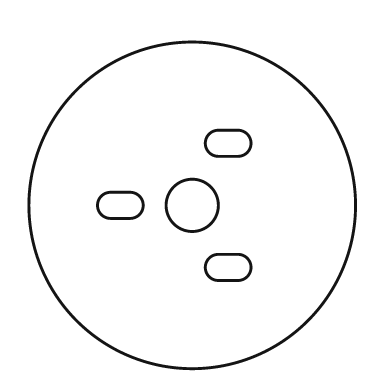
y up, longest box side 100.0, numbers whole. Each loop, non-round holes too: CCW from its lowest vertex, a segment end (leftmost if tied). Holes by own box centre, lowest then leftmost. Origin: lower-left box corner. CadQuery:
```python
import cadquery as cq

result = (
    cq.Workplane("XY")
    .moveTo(50.0, 50.0)
    .circle(50.0)
    .moveTo(58.0, 27.0)
    .lineTo(64.0, 27.0)
    .threePointArc((68.0, 31.0), (64.0, 35.0))
    .lineTo(58.0, 35.0)
    .threePointArc((54.0, 31.0), (58.0, 27.0))
    .close()
    .moveTo(25.0, 46.0)
    .lineTo(31.0, 46.0)
    .threePointArc((35.0, 50.0), (31.0, 54.0))
    .lineTo(25.0, 54.0)
    .threePointArc((21.0, 50.0), (25.0, 46.0))
    .close()
    .moveTo(50.0, 50.0)
    .circle(8.0)
    .moveTo(58.0, 65.0)
    .lineTo(64.0, 65.0)
    .threePointArc((68.0, 69.0), (64.0, 73.0))
    .lineTo(58.0, 73.0)
    .threePointArc((54.0, 69.0), (58.0, 65.0))
    .close()
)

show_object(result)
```